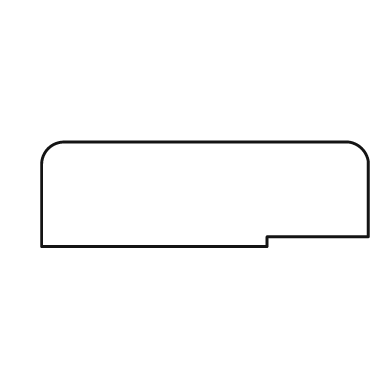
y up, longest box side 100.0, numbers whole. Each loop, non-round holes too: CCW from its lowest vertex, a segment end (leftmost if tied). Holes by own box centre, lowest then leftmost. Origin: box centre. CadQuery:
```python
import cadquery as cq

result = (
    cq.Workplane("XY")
    .moveTo(-50.0, -16.0)
    .lineTo(19.0, -16.0)
    .lineTo(19.0, -13.0)
    .lineTo(50.0, -13.0)
    .lineTo(50.0, 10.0)
    .threePointArc((48.0, 14.0), (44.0, 16.0))
    .lineTo(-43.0, 16.0)
    .threePointArc((-48.0, 14.0), (-50.0, 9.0))
    .close()
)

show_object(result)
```